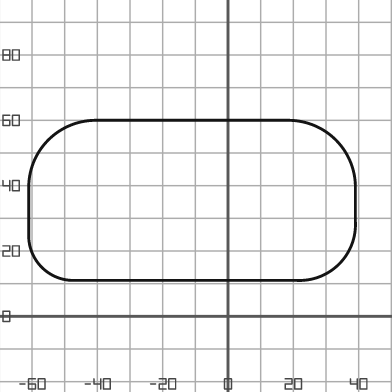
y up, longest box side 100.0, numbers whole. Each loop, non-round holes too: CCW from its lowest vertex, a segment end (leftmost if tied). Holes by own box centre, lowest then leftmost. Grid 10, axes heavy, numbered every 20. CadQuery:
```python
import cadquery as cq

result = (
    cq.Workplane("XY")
    .moveTo(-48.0, 11.0)
    .lineTo(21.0, 11.0)
    .threePointArc((34.0, 16.0), (39.0, 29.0))
    .lineTo(39.0, 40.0)
    .threePointArc((33.0, 54.0), (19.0, 60.0))
    .lineTo(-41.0, 60.0)
    .threePointArc((-55.0, 54.0), (-61.0, 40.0))
    .lineTo(-61.0, 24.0)
    .threePointArc((-57.0, 15.0), (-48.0, 11.0))
    .close()
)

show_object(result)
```